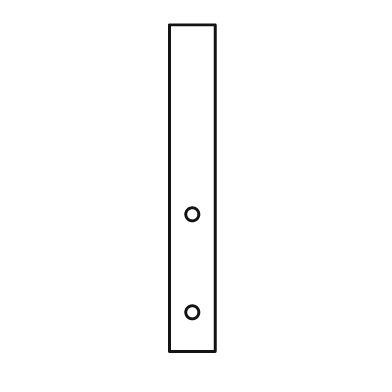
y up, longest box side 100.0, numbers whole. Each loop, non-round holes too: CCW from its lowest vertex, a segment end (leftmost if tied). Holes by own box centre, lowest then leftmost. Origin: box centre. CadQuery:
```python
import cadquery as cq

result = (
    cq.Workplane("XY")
    .moveTo(-7.0, -50.0)
    .lineTo(7.0, -50.0)
    .lineTo(7.0, 50.0)
    .lineTo(-7.0, 50.0)
    .close()
    .moveTo(0.0, -38.0)
    .circle(2.0)
    .moveTo(0.0, -8.0)
    .circle(2.0)
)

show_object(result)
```